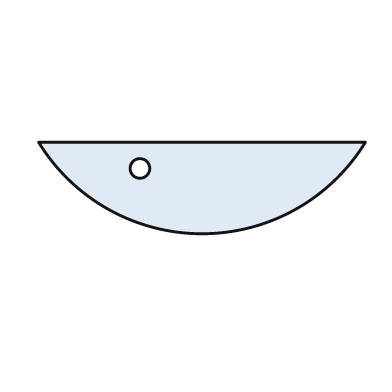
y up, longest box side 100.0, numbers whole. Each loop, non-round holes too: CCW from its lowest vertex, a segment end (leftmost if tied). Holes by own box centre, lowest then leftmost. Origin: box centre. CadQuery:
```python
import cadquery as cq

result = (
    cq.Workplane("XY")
    .moveTo(-50.0, 14.0)
    .threePointArc((0.0, -14.0), (50.0, 14.0))
    .close()
    .moveTo(-19.0, 6.0)
    .circle(3.0)
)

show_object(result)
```